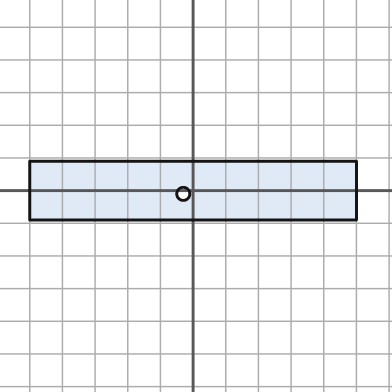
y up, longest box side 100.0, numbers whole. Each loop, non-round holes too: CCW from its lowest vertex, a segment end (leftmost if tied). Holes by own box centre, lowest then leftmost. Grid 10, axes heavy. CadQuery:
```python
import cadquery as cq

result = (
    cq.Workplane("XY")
    .moveTo(-50.0, -9.0)
    .lineTo(50.0, -9.0)
    .lineTo(50.0, 9.0)
    .lineTo(-50.0, 9.0)
    .close()
    .moveTo(-3.0, -1.0)
    .circle(2.0)
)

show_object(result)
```